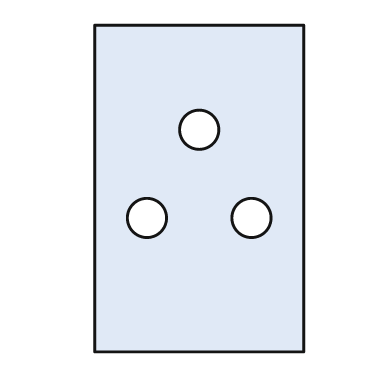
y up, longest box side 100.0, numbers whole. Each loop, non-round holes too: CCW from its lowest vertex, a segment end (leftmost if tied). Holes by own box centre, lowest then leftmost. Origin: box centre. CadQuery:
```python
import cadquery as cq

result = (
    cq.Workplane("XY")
    .moveTo(-32.0, -50.0)
    .lineTo(32.0, -50.0)
    .lineTo(32.0, 50.0)
    .lineTo(-32.0, 50.0)
    .close()
    .moveTo(-16.0, -9.0)
    .circle(6.0)
    .moveTo(16.0, -9.0)
    .circle(6.0)
    .moveTo(0.0, 18.0)
    .circle(6.0)
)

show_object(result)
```